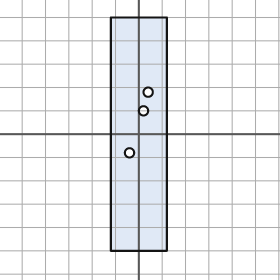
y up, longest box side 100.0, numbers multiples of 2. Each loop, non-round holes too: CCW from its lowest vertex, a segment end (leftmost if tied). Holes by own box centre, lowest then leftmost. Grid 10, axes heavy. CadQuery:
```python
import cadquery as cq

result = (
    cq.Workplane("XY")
    .moveTo(-12.0, -50.0)
    .lineTo(12.0, -50.0)
    .lineTo(12.0, 50.0)
    .lineTo(-12.0, 50.0)
    .close()
    .moveTo(-4.0, -8.0)
    .circle(2.0)
    .moveTo(2.0, 10.0)
    .circle(2.0)
    .moveTo(4.0, 18.0)
    .circle(2.0)
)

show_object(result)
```